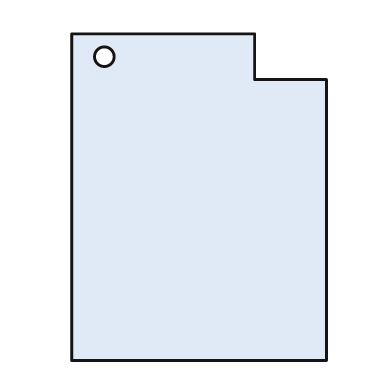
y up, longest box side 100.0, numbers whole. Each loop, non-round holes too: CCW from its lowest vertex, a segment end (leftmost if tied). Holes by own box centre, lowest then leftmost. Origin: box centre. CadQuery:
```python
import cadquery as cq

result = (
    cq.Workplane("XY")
    .moveTo(-39.0, -50.0)
    .lineTo(39.0, -50.0)
    .lineTo(39.0, 36.0)
    .lineTo(17.0, 36.0)
    .lineTo(17.0, 50.0)
    .lineTo(-39.0, 50.0)
    .close()
    .moveTo(-29.0, 43.0)
    .circle(3.0)
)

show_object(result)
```